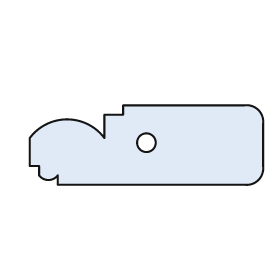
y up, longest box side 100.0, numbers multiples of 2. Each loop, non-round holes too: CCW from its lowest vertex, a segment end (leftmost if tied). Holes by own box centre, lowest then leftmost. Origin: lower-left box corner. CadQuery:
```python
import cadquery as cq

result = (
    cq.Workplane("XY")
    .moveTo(12.0, 0.0)
    .lineTo(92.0, 0.0)
    .threePointArc((98.0, 2.0), (100.0, 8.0))
    .lineTo(100.0, 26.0)
    .threePointArc((98.0, 32.0), (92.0, 34.0))
    .lineTo(40.0, 34.0)
    .lineTo(40.0, 30.0)
    .lineTo(32.0, 30.0)
    .lineTo(32.0, 20.0)
    .threePointArc((16.0, 28.0), (0.0, 20.0))
    .lineTo(0.0, 8.0)
    .lineTo(4.0, 8.0)
    .lineTo(4.0, 4.0)
    .threePointArc((8.0, 2.0), (12.0, 4.0))
    .close()
    .moveTo(50.0, 18.0)
    .circle(4.0)
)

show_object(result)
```